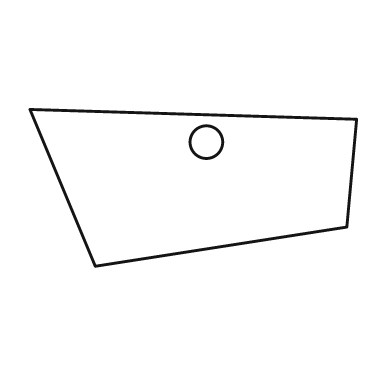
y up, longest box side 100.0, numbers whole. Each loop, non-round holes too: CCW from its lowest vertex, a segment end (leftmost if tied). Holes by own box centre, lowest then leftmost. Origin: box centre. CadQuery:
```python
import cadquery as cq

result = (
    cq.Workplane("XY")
    .moveTo(-30.0, -24.0)
    .lineTo(47.0, -12.0)
    .lineTo(50.0, 21.0)
    .lineTo(-50.0, 24.0)
    .close()
    .moveTo(4.0, 14.0)
    .circle(5.0)
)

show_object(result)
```